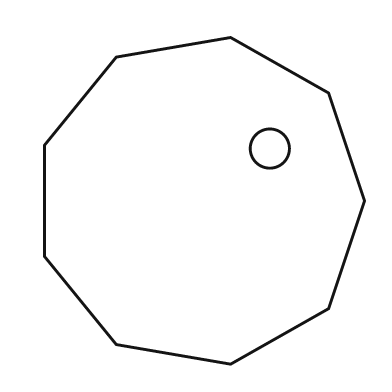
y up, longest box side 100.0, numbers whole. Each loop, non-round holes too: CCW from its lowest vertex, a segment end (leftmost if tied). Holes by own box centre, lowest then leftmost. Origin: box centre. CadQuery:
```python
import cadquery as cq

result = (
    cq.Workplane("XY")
    .moveTo(8.0, -50.0)
    .lineTo(38.0, -33.0)
    .lineTo(49.0, 0.0)
    .lineTo(38.0, 33.0)
    .lineTo(8.0, 50.0)
    .lineTo(-27.0, 44.0)
    .lineTo(-49.0, 17.0)
    .lineTo(-49.0, -17.0)
    .lineTo(-27.0, -44.0)
    .close()
    .moveTo(20.0, 16.0)
    .circle(6.0)
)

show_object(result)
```